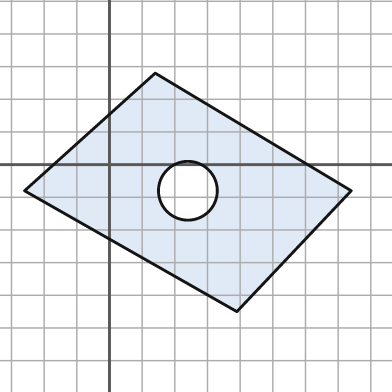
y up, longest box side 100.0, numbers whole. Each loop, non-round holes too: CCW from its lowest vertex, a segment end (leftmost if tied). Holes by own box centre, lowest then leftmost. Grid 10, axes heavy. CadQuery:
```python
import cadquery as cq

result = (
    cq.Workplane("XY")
    .moveTo(39.0, -45.0)
    .lineTo(74.0, -8.0)
    .lineTo(14.0, 28.0)
    .lineTo(-26.0, -8.0)
    .close()
    .moveTo(24.0, -8.0)
    .circle(9.0)
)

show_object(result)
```